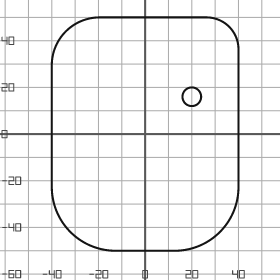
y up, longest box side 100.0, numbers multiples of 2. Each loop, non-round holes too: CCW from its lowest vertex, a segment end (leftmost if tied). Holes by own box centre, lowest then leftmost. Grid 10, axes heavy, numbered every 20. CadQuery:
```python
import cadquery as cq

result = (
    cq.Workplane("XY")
    .moveTo(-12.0, -50.0)
    .lineTo(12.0, -50.0)
    .threePointArc((32.0, -42.0), (40.0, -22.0))
    .lineTo(40.0, 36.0)
    .threePointArc((36.0, 46.0), (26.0, 50.0))
    .lineTo(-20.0, 50.0)
    .threePointArc((-34.0, 44.0), (-40.0, 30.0))
    .lineTo(-40.0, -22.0)
    .threePointArc((-32.0, -42.0), (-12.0, -50.0))
    .close()
    .moveTo(20.0, 16.0)
    .circle(4.0)
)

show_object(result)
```